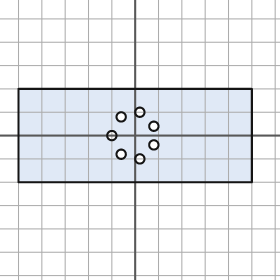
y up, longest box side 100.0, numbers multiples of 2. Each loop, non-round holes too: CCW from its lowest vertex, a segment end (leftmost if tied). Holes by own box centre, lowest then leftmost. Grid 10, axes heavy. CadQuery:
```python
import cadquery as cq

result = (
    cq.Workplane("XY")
    .moveTo(-50.0, -20.0)
    .lineTo(50.0, -20.0)
    .lineTo(50.0, 20.0)
    .lineTo(-50.0, 20.0)
    .close()
    .moveTo(2.0, -10.0)
    .circle(2.0)
    .moveTo(-6.0, -8.0)
    .circle(2.0)
    .moveTo(8.0, -4.0)
    .circle(2.0)
    .moveTo(-10.0, 0.0)
    .circle(2.0)
    .moveTo(8.0, 4.0)
    .circle(2.0)
    .moveTo(-6.0, 8.0)
    .circle(2.0)
    .moveTo(2.0, 10.0)
    .circle(2.0)
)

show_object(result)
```